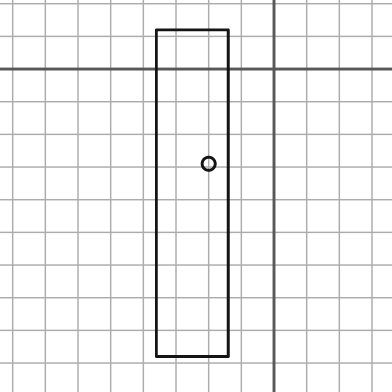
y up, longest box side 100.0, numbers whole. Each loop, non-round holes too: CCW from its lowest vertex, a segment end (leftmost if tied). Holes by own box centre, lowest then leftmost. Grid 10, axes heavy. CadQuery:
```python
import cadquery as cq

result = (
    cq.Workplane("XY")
    .moveTo(-36.0, -88.0)
    .lineTo(-14.0, -88.0)
    .lineTo(-14.0, 12.0)
    .lineTo(-36.0, 12.0)
    .close()
    .moveTo(-20.0, -29.0)
    .circle(2.0)
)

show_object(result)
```